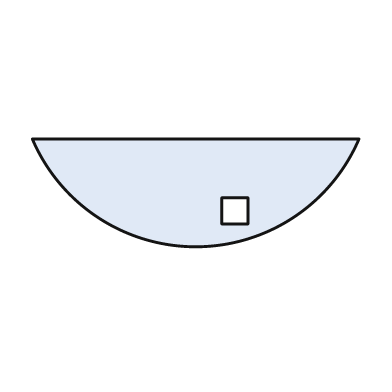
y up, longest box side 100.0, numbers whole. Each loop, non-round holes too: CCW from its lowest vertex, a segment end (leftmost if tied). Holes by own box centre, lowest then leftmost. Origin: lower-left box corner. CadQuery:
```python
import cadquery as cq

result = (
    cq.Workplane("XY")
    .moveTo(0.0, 33.0)
    .threePointArc((50.0, 0.0), (100.0, 33.0))
    .close()
    .moveTo(58.0, 7.0)
    .lineTo(66.0, 7.0)
    .lineTo(66.0, 15.0)
    .lineTo(58.0, 15.0)
    .close()
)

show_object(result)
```